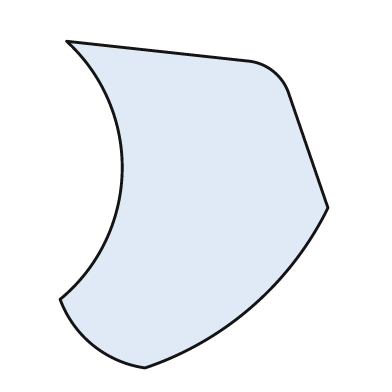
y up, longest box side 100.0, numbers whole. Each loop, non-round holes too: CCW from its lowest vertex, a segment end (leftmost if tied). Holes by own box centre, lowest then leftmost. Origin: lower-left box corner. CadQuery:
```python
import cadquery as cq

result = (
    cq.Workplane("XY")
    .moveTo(26.0, 0.0)
    .threePointArc((59.0, 19.0), (82.0, 49.0))
    .lineTo(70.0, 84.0)
    .threePointArc((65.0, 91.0), (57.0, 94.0))
    .lineTo(2.0, 100.0)
    .threePointArc((19.0, 60.0), (0.0, 21.0))
    .threePointArc((10.0, 7.0), (26.0, 0.0))
    .close()
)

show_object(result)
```